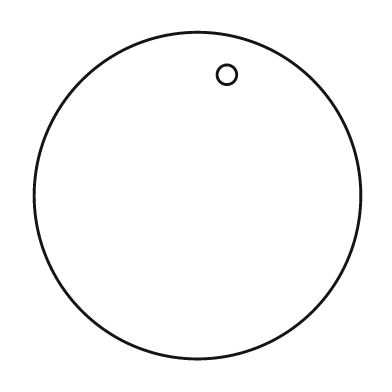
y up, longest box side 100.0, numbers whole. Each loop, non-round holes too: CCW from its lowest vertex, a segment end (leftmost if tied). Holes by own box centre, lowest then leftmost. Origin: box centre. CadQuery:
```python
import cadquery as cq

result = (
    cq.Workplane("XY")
    .moveTo(0.0, 0.0)
    .circle(50.0)
    .moveTo(9.0, 37.0)
    .circle(3.0)
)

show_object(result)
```